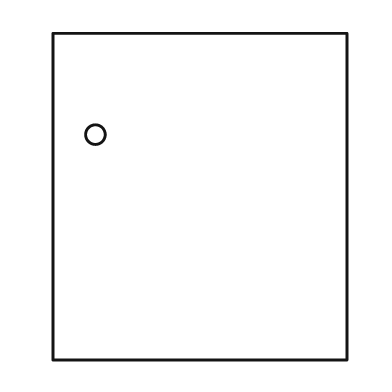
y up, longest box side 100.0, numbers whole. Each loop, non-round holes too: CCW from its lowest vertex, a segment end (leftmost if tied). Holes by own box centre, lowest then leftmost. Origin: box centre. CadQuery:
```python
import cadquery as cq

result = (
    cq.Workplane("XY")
    .moveTo(-45.0, -50.0)
    .lineTo(45.0, -50.0)
    .lineTo(45.0, 50.0)
    .lineTo(-45.0, 50.0)
    .close()
    .moveTo(-32.0, 19.0)
    .circle(3.0)
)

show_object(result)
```